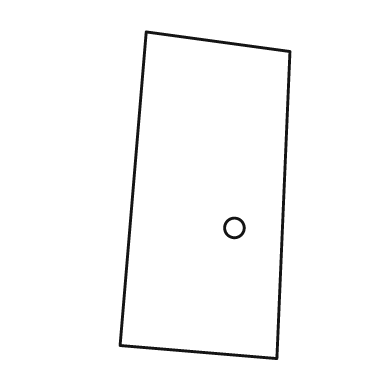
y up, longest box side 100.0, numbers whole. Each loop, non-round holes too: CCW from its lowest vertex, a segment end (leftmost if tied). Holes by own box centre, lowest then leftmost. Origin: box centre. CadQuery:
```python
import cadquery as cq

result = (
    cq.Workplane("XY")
    .moveTo(22.0, -50.0)
    .lineTo(26.0, 44.0)
    .lineTo(-18.0, 50.0)
    .lineTo(-26.0, -46.0)
    .close()
    .moveTo(9.0, -10.0)
    .circle(3.0)
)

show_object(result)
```